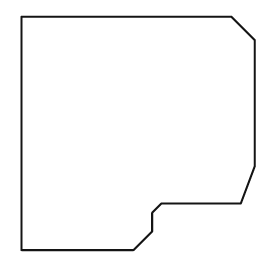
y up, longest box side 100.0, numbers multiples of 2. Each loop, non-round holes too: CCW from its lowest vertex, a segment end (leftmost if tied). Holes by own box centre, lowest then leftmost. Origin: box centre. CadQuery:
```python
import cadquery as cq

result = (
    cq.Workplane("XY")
    .moveTo(-50.0, -50.0)
    .lineTo(-2.0, -50.0)
    .lineTo(6.0, -42.0)
    .lineTo(6.0, -34.0)
    .lineTo(10.0, -30.0)
    .lineTo(44.0, -30.0)
    .lineTo(50.0, -14.0)
    .lineTo(50.0, 40.0)
    .lineTo(40.0, 50.0)
    .lineTo(-50.0, 50.0)
    .close()
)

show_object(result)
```